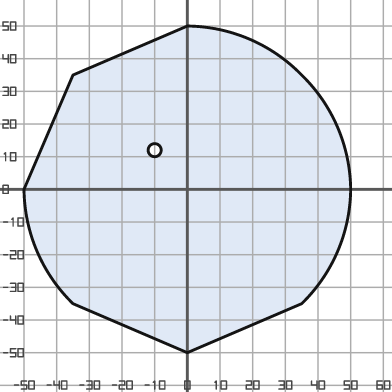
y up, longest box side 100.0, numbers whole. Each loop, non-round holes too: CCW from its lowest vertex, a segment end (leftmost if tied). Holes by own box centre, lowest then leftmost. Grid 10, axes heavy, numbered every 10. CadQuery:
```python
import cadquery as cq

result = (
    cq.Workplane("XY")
    .moveTo(0.0, -50.0)
    .lineTo(35.0, -35.0)
    .threePointArc((46.0, -19.0), (50.0, 0.0))
    .threePointArc((46.0, 19.0), (35.0, 35.0))
    .threePointArc((19.0, 46.0), (0.0, 50.0))
    .lineTo(-35.0, 35.0)
    .lineTo(-50.0, 0.0)
    .threePointArc((-46.0, -19.0), (-35.0, -35.0))
    .close()
    .moveTo(-10.0, 12.0)
    .circle(2.0)
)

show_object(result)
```